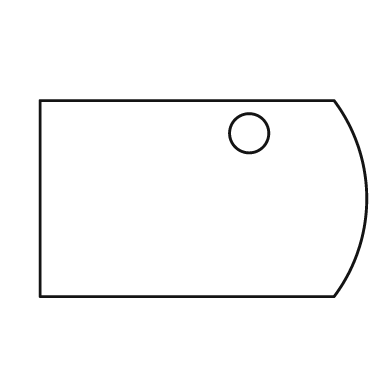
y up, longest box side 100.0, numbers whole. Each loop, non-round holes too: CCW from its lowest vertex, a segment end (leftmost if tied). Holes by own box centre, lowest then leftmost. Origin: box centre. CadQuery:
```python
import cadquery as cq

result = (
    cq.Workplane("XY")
    .moveTo(-50.0, -30.0)
    .lineTo(40.0, -30.0)
    .threePointArc((50.0, 0.0), (40.0, 30.0))
    .lineTo(-50.0, 30.0)
    .close()
    .moveTo(14.0, 20.0)
    .circle(6.0)
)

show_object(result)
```